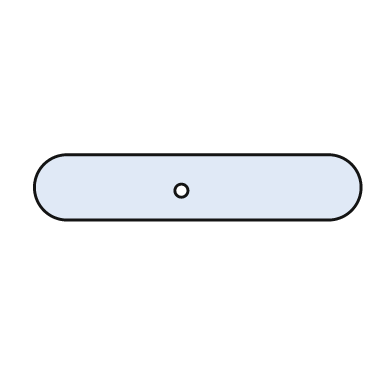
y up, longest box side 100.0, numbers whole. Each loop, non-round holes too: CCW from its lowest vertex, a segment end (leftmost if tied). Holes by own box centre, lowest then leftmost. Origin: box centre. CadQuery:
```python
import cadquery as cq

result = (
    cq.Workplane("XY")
    .moveTo(-40.0, -10.0)
    .lineTo(40.0, -10.0)
    .threePointArc((50.0, 0.0), (40.0, 10.0))
    .lineTo(-40.0, 10.0)
    .threePointArc((-50.0, 0.0), (-40.0, -10.0))
    .close()
    .moveTo(-5.0, -1.0)
    .circle(2.0)
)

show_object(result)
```